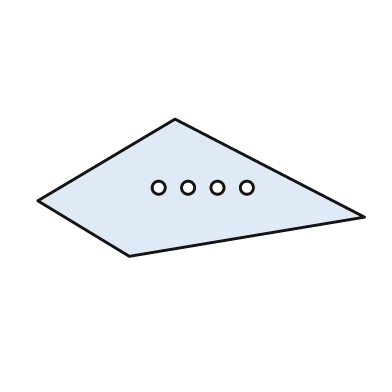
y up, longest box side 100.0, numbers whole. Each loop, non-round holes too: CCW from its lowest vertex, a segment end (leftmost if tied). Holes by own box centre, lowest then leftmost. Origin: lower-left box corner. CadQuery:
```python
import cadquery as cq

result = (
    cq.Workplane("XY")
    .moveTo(28.0, 0.0)
    .lineTo(100.0, 12.0)
    .lineTo(42.0, 42.0)
    .lineTo(0.0, 17.0)
    .close()
    .moveTo(37.0, 21.0)
    .circle(2.0)
    .moveTo(46.0, 21.0)
    .circle(2.0)
    .moveTo(55.0, 21.0)
    .circle(2.0)
    .moveTo(64.0, 21.0)
    .circle(2.0)
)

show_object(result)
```